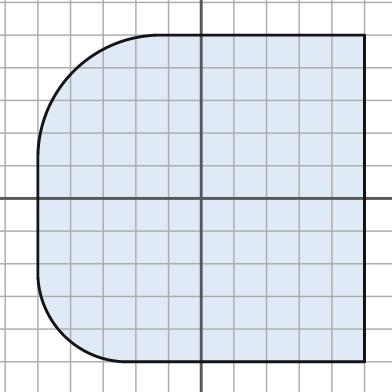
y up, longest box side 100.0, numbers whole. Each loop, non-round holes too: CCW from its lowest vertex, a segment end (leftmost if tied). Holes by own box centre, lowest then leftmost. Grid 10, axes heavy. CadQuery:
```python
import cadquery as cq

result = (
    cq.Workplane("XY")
    .moveTo(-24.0, -50.0)
    .lineTo(50.0, -50.0)
    .lineTo(50.0, 50.0)
    .lineTo(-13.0, 50.0)
    .threePointArc((-39.0, 39.0), (-50.0, 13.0))
    .lineTo(-50.0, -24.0)
    .threePointArc((-42.0, -42.0), (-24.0, -50.0))
    .close()
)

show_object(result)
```